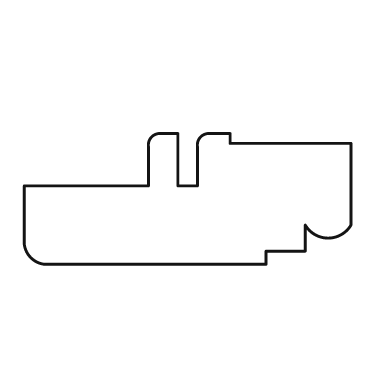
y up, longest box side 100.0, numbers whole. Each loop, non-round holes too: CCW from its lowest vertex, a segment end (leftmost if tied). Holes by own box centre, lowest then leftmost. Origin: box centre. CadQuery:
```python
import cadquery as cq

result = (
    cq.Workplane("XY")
    .moveTo(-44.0, -20.0)
    .lineTo(24.0, -20.0)
    .lineTo(24.0, -16.0)
    .lineTo(36.0, -16.0)
    .lineTo(36.0, -8.0)
    .threePointArc((43.0, -12.0), (50.0, -8.0))
    .lineTo(50.0, 17.0)
    .lineTo(13.0, 17.0)
    .lineTo(13.0, 20.0)
    .lineTo(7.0, 20.0)
    .threePointArc((4.0, 19.0), (3.0, 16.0))
    .lineTo(3.0, 4.0)
    .lineTo(-3.0, 4.0)
    .lineTo(-3.0, 20.0)
    .lineTo(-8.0, 20.0)
    .threePointArc((-11.0, 19.0), (-12.0, 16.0))
    .lineTo(-12.0, 4.0)
    .lineTo(-50.0, 4.0)
    .lineTo(-50.0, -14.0)
    .threePointArc((-48.0, -18.0), (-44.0, -20.0))
    .close()
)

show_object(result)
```